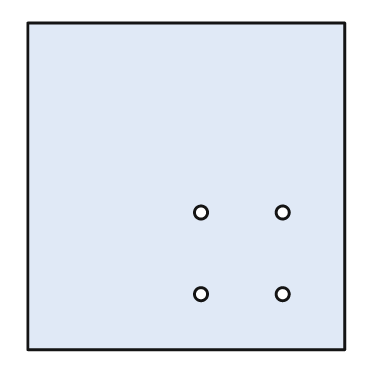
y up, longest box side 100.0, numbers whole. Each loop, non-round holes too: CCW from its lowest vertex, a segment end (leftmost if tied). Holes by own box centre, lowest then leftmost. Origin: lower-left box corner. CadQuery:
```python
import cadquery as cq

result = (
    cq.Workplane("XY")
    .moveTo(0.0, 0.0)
    .lineTo(97.0, 0.0)
    .lineTo(97.0, 100.0)
    .lineTo(0.0, 100.0)
    .close()
    .moveTo(53.0, 17.0)
    .circle(2.0)
    .moveTo(78.0, 17.0)
    .circle(2.0)
    .moveTo(53.0, 42.0)
    .circle(2.0)
    .moveTo(78.0, 42.0)
    .circle(2.0)
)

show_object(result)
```